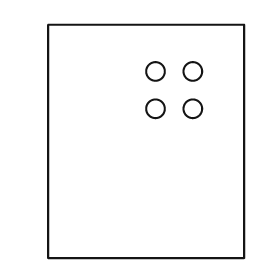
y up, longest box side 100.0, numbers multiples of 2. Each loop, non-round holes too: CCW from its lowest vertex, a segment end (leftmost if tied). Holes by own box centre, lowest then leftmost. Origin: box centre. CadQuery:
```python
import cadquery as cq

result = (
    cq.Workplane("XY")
    .moveTo(-42.0, -50.0)
    .lineTo(42.0, -50.0)
    .lineTo(42.0, 50.0)
    .lineTo(-42.0, 50.0)
    .close()
    .moveTo(4.0, 14.0)
    .circle(4.0)
    .moveTo(20.0, 14.0)
    .circle(4.0)
    .moveTo(4.0, 30.0)
    .circle(4.0)
    .moveTo(20.0, 30.0)
    .circle(4.0)
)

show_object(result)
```